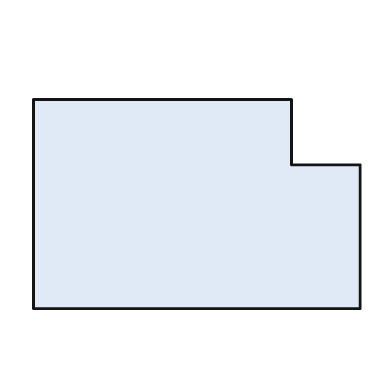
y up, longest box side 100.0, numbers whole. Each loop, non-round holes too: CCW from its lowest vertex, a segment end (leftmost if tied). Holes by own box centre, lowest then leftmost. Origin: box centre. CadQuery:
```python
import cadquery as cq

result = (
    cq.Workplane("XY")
    .moveTo(-50.0, -32.0)
    .lineTo(50.0, -32.0)
    .lineTo(50.0, 12.0)
    .lineTo(29.0, 12.0)
    .lineTo(29.0, 32.0)
    .lineTo(-50.0, 32.0)
    .close()
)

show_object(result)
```